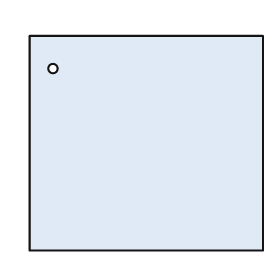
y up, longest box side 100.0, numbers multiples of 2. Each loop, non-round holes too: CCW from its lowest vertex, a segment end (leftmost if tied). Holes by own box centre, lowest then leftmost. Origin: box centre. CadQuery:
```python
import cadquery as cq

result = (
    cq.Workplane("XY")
    .moveTo(-50.0, -46.0)
    .lineTo(50.0, -46.0)
    .lineTo(50.0, 46.0)
    .lineTo(-50.0, 46.0)
    .close()
    .moveTo(-40.0, 32.0)
    .circle(2.0)
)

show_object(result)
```